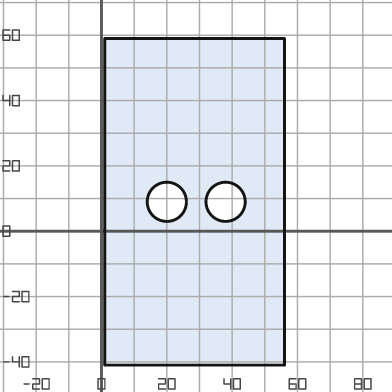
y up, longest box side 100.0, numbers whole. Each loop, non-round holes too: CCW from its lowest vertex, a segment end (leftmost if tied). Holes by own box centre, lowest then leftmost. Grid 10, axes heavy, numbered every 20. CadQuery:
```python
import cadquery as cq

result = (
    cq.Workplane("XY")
    .moveTo(1.0, -41.0)
    .lineTo(56.0, -41.0)
    .lineTo(56.0, 59.0)
    .lineTo(1.0, 59.0)
    .close()
    .moveTo(20.0, 9.0)
    .circle(6.0)
    .moveTo(38.0, 9.0)
    .circle(6.0)
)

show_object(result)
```